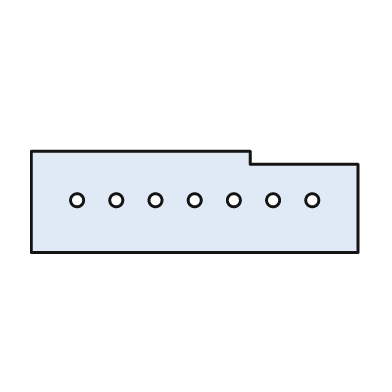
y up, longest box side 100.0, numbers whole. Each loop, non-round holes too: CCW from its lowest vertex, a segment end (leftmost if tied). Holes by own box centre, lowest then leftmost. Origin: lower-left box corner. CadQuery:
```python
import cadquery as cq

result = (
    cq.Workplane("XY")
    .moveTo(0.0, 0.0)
    .lineTo(100.0, 0.0)
    .lineTo(100.0, 27.0)
    .lineTo(67.0, 27.0)
    .lineTo(67.0, 31.0)
    .lineTo(0.0, 31.0)
    .close()
    .moveTo(14.0, 16.0)
    .circle(2.0)
    .moveTo(26.0, 16.0)
    .circle(2.0)
    .moveTo(38.0, 16.0)
    .circle(2.0)
    .moveTo(50.0, 16.0)
    .circle(2.0)
    .moveTo(62.0, 16.0)
    .circle(2.0)
    .moveTo(74.0, 16.0)
    .circle(2.0)
    .moveTo(86.0, 16.0)
    .circle(2.0)
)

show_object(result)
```